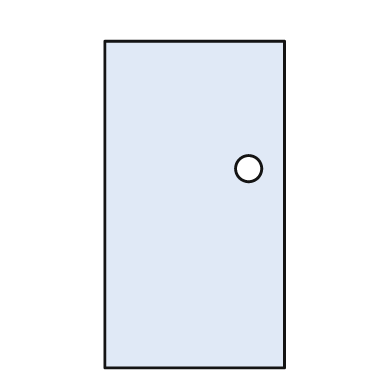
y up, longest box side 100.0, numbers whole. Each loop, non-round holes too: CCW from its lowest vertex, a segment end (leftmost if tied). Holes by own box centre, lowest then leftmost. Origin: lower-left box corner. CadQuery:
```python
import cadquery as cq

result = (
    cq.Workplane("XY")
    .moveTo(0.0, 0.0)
    .lineTo(55.0, 0.0)
    .lineTo(55.0, 100.0)
    .lineTo(0.0, 100.0)
    .close()
    .moveTo(44.0, 61.0)
    .circle(4.0)
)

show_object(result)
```